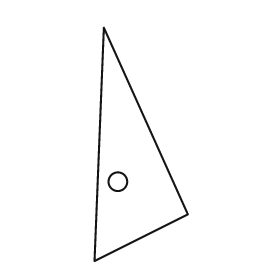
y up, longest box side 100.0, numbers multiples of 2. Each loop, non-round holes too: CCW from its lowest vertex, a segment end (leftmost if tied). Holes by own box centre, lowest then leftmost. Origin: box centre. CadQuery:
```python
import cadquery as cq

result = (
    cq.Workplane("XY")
    .moveTo(-20.0, -50.0)
    .lineTo(20.0, -30.0)
    .lineTo(-16.0, 50.0)
    .close()
    .moveTo(-10.0, -16.0)
    .circle(4.0)
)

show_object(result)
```